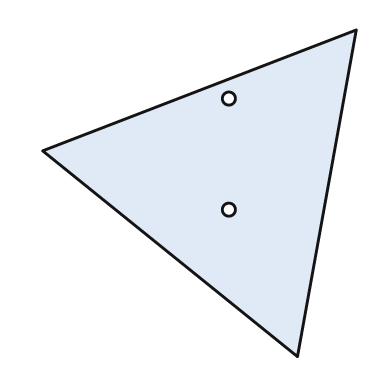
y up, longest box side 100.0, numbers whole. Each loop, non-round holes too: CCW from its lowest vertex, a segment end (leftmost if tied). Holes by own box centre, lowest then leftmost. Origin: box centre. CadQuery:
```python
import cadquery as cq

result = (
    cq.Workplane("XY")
    .moveTo(30.0, -50.0)
    .lineTo(48.0, 50.0)
    .lineTo(-48.0, 13.0)
    .close()
    .moveTo(9.0, -5.0)
    .circle(2.0)
    .moveTo(9.0, 29.0)
    .circle(2.0)
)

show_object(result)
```